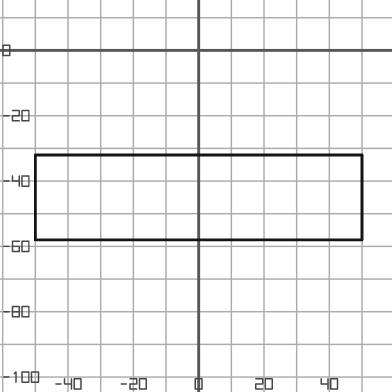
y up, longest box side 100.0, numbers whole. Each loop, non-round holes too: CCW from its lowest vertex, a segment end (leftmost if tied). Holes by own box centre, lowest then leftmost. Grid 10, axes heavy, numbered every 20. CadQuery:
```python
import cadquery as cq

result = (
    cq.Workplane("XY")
    .moveTo(-50.0, -58.0)
    .lineTo(50.0, -58.0)
    .lineTo(50.0, -32.0)
    .lineTo(-50.0, -32.0)
    .close()
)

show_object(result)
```